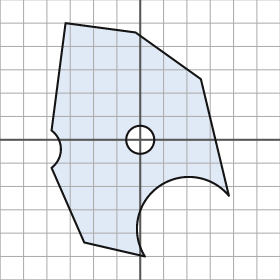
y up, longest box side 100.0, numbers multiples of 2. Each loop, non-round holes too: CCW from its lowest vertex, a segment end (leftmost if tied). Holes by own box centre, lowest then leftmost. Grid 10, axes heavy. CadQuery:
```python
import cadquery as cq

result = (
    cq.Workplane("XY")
    .moveTo(2.0, -50.0)
    .threePointArc((8.0, -20.0), (38.0, -24.0))
    .lineTo(26.0, 26.0)
    .lineTo(-2.0, 46.0)
    .lineTo(-32.0, 50.0)
    .lineTo(-38.0, 4.0)
    .threePointArc((-34.0, -4.0), (-38.0, -12.0))
    .lineTo(-24.0, -44.0)
    .close()
    .moveTo(0.0, 0.0)
    .circle(6.0)
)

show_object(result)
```